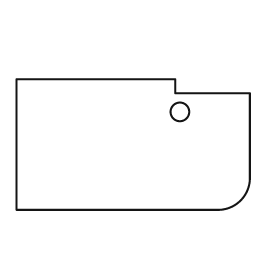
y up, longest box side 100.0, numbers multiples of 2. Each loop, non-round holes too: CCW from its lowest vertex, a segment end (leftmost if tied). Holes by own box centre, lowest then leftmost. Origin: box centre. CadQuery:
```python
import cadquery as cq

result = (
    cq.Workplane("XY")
    .moveTo(-50.0, -28.0)
    .lineTo(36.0, -28.0)
    .threePointArc((46.0, -24.0), (50.0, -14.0))
    .lineTo(50.0, 22.0)
    .lineTo(18.0, 22.0)
    .lineTo(18.0, 28.0)
    .lineTo(-50.0, 28.0)
    .close()
    .moveTo(20.0, 14.0)
    .circle(4.0)
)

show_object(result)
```